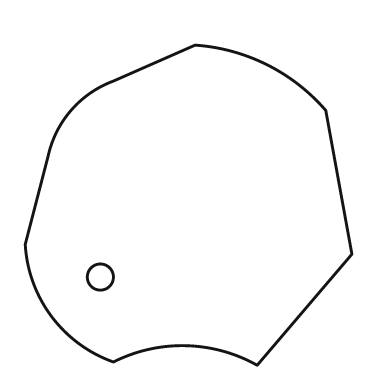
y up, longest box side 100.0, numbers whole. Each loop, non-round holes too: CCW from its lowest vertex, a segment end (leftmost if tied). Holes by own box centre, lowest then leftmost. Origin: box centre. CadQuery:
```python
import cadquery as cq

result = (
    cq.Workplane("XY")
    .moveTo(21.0, -49.0)
    .lineTo(50.0, -15.0)
    .lineTo(42.0, 29.0)
    .threePointArc((24.0, 43.0), (2.0, 49.0))
    .lineTo(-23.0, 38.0)
    .threePointArc((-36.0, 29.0), (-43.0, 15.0))
    .lineTo(-50.0, -12.0)
    .threePointArc((-42.0, -34.0), (-23.0, -48.0))
    .threePointArc((-1.0, -43.0), (21.0, -49.0))
    .close()
    .moveTo(-27.0, -22.0)
    .circle(4.0)
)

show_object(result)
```